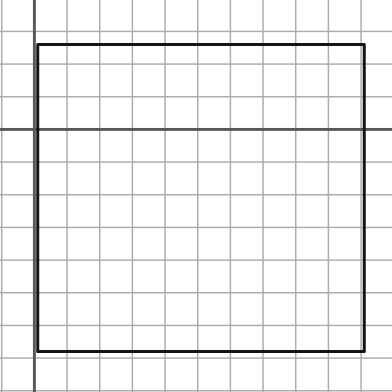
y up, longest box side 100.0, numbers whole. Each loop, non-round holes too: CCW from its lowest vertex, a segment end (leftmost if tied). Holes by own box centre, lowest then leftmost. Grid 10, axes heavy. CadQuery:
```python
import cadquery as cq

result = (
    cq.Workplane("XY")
    .moveTo(1.0, -68.0)
    .lineTo(101.0, -68.0)
    .lineTo(101.0, 26.0)
    .lineTo(1.0, 26.0)
    .close()
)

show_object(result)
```